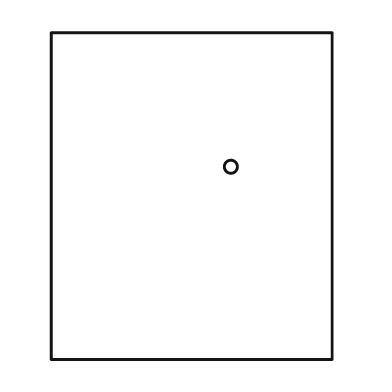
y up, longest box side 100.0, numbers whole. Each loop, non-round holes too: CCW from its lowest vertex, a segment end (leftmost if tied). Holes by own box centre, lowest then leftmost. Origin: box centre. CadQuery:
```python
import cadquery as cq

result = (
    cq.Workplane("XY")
    .moveTo(-43.0, -50.0)
    .lineTo(43.0, -50.0)
    .lineTo(43.0, 50.0)
    .lineTo(-43.0, 50.0)
    .close()
    .moveTo(12.0, 9.0)
    .circle(2.0)
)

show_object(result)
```